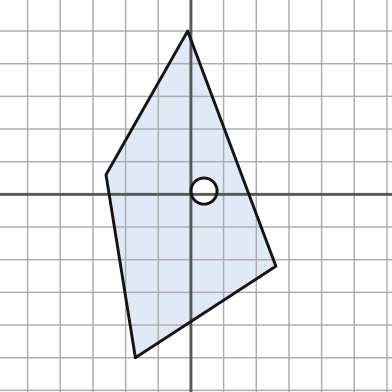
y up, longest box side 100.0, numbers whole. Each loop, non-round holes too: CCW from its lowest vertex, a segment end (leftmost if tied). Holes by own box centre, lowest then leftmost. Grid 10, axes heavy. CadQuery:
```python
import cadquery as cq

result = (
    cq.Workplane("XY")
    .moveTo(-17.0, -50.0)
    .lineTo(26.0, -22.0)
    .lineTo(-1.0, 50.0)
    .lineTo(-26.0, 6.0)
    .close()
    .moveTo(4.0, 1.0)
    .circle(4.0)
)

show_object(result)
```